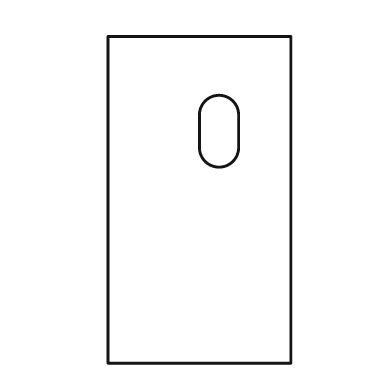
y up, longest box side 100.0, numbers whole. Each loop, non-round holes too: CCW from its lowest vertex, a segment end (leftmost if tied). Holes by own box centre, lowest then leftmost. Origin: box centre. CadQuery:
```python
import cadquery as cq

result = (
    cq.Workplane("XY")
    .moveTo(-28.0, -50.0)
    .lineTo(28.0, -50.0)
    .lineTo(28.0, 50.0)
    .lineTo(-28.0, 50.0)
    .close()
    .moveTo(0.0, 16.0)
    .threePointArc((6.0, 10.0), (12.0, 16.0))
    .lineTo(12.0, 26.0)
    .threePointArc((6.0, 32.0), (0.0, 26.0))
    .close()
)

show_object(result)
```